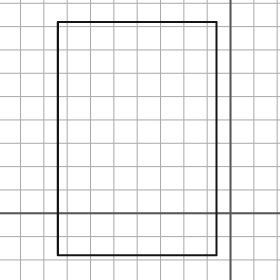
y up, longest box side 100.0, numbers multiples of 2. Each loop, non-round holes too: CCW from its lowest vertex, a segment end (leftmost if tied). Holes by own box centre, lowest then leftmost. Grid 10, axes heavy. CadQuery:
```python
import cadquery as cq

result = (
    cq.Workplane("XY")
    .moveTo(-74.0, -18.0)
    .lineTo(-6.0, -18.0)
    .lineTo(-6.0, 82.0)
    .lineTo(-74.0, 82.0)
    .close()
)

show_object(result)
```